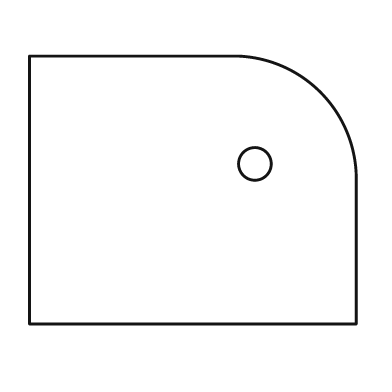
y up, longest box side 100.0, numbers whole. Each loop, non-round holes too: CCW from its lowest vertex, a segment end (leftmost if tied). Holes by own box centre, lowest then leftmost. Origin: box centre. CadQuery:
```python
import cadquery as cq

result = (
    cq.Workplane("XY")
    .moveTo(-50.0, -41.0)
    .lineTo(50.0, -41.0)
    .lineTo(50.0, 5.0)
    .threePointArc((39.0, 30.0), (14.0, 41.0))
    .lineTo(-50.0, 41.0)
    .close()
    .moveTo(19.0, 8.0)
    .circle(5.0)
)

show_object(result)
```